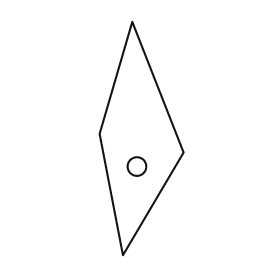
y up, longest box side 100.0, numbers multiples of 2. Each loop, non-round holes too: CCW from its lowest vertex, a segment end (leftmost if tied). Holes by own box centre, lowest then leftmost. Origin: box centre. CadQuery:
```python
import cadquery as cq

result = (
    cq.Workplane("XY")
    .moveTo(-8.0, -50.0)
    .lineTo(18.0, -6.0)
    .lineTo(-4.0, 50.0)
    .lineTo(-18.0, 2.0)
    .close()
    .moveTo(-2.0, -12.0)
    .circle(4.0)
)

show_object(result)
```